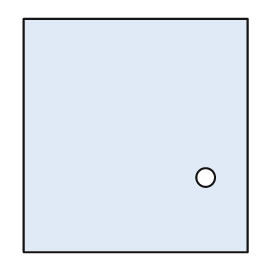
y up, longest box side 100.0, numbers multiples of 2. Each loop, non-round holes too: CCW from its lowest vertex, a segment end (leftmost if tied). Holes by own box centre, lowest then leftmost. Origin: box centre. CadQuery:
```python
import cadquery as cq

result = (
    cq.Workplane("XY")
    .moveTo(-48.0, -50.0)
    .lineTo(48.0, -50.0)
    .lineTo(48.0, 50.0)
    .lineTo(-48.0, 50.0)
    .close()
    .moveTo(30.0, -18.0)
    .circle(4.0)
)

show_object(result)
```